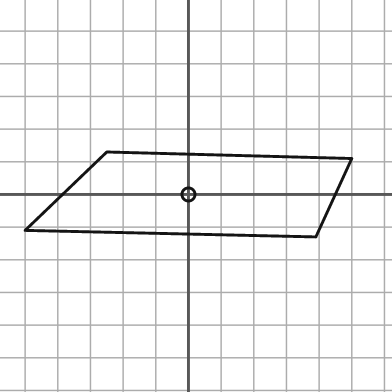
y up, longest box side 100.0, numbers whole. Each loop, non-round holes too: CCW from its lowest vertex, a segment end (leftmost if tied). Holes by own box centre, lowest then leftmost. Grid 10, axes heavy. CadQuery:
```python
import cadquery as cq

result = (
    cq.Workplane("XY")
    .moveTo(39.0, -13.0)
    .lineTo(50.0, 11.0)
    .lineTo(-25.0, 13.0)
    .lineTo(-50.0, -11.0)
    .close()
    .moveTo(0.0, 0.0)
    .circle(2.0)
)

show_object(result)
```